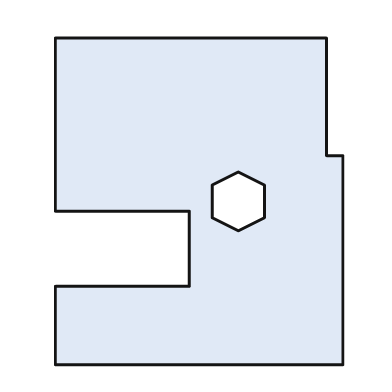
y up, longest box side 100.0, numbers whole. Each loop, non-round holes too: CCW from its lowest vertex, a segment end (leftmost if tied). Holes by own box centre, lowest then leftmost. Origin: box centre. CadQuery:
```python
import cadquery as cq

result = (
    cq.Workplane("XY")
    .moveTo(-44.0, -50.0)
    .lineTo(44.0, -50.0)
    .lineTo(44.0, 14.0)
    .lineTo(39.0, 14.0)
    .lineTo(39.0, 50.0)
    .lineTo(-44.0, 50.0)
    .lineTo(-44.0, -3.0)
    .lineTo(-3.0, -3.0)
    .lineTo(-3.0, -26.0)
    .lineTo(-44.0, -26.0)
    .close()
    .moveTo(12.0, -9.0)
    .lineTo(20.0, -5.0)
    .lineTo(20.0, 5.0)
    .lineTo(12.0, 9.0)
    .lineTo(4.0, 5.0)
    .lineTo(4.0, -5.0)
    .close()
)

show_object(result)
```